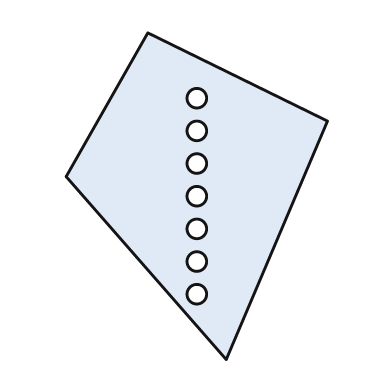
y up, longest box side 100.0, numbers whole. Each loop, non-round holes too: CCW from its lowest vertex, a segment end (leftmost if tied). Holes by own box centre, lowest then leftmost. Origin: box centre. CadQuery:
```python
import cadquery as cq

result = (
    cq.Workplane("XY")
    .moveTo(9.0, -50.0)
    .lineTo(40.0, 23.0)
    .lineTo(-15.0, 50.0)
    .lineTo(-40.0, 6.0)
    .close()
    .moveTo(0.0, -30.0)
    .circle(3.0)
    .moveTo(0.0, -20.0)
    .circle(3.0)
    .moveTo(0.0, -10.0)
    .circle(3.0)
    .moveTo(0.0, 0.0)
    .circle(3.0)
    .moveTo(0.0, 10.0)
    .circle(3.0)
    .moveTo(0.0, 20.0)
    .circle(3.0)
    .moveTo(0.0, 30.0)
    .circle(3.0)
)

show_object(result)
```